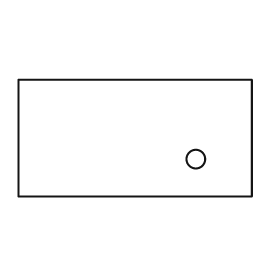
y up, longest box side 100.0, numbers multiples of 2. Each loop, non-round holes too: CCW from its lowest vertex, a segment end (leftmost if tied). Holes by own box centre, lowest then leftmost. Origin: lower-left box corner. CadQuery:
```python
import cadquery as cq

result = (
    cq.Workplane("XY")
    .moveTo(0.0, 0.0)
    .lineTo(100.0, 0.0)
    .lineTo(100.0, 50.0)
    .lineTo(0.0, 50.0)
    .close()
    .moveTo(76.0, 16.0)
    .circle(4.0)
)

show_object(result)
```